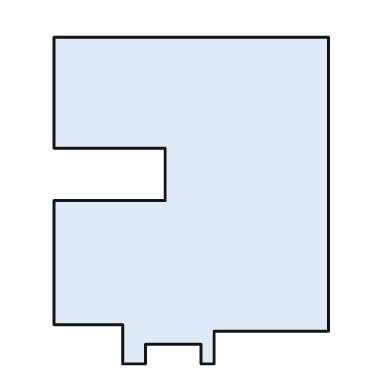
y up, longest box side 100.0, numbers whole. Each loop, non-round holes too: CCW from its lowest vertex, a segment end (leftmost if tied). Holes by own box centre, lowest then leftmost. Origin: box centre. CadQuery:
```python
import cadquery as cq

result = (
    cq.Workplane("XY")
    .moveTo(-21.0, -50.0)
    .lineTo(-14.0, -50.0)
    .lineTo(-14.0, -44.0)
    .lineTo(3.0, -44.0)
    .lineTo(3.0, -50.0)
    .lineTo(7.0, -50.0)
    .lineTo(7.0, -40.0)
    .lineTo(42.0, -40.0)
    .lineTo(42.0, 50.0)
    .lineTo(-42.0, 50.0)
    .lineTo(-42.0, 16.0)
    .lineTo(-8.0, 16.0)
    .lineTo(-8.0, 0.0)
    .lineTo(-42.0, 0.0)
    .lineTo(-42.0, -38.0)
    .lineTo(-21.0, -38.0)
    .close()
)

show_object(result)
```